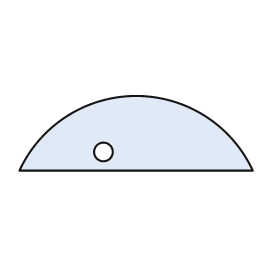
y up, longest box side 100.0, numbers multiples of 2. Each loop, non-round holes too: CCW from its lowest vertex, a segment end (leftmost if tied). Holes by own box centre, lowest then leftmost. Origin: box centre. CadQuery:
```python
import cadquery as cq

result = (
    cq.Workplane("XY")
    .moveTo(-50.0, -16.0)
    .lineTo(50.0, -16.0)
    .threePointArc((0.0, 16.0), (-50.0, -16.0))
    .close()
    .moveTo(-14.0, -8.0)
    .circle(4.0)
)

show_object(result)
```